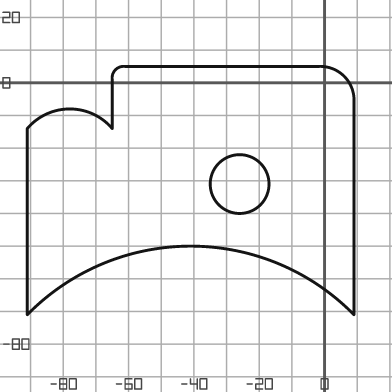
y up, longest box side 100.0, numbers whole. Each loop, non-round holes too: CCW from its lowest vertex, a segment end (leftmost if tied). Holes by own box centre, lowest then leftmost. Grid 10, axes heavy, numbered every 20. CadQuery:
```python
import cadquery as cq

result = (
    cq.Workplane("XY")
    .moveTo(-91.0, -71.0)
    .threePointArc((-41.0, -50.0), (9.0, -71.0))
    .lineTo(9.0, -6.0)
    .threePointArc((6.0, 2.0), (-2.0, 5.0))
    .lineTo(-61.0, 5.0)
    .threePointArc((-64.0, 4.0), (-65.0, 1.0))
    .lineTo(-65.0, -14.0)
    .threePointArc((-78.0, -8.0), (-91.0, -14.0))
    .close()
    .moveTo(-26.0, -31.0)
    .circle(9.0)
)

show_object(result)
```